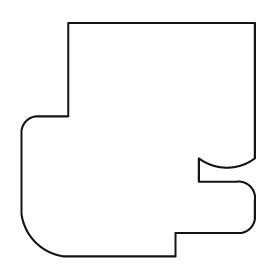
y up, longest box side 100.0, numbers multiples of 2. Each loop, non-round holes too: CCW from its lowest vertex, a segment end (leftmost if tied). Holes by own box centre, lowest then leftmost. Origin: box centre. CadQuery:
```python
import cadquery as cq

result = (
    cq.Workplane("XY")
    .moveTo(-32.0, -50.0)
    .lineTo(16.0, -50.0)
    .lineTo(16.0, -40.0)
    .lineTo(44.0, -40.0)
    .threePointArc((48.0, -38.0), (50.0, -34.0))
    .lineTo(50.0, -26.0)
    .threePointArc((48.0, -20.0), (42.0, -18.0))
    .lineTo(26.0, -18.0)
    .lineTo(26.0, -8.0)
    .threePointArc((38.0, -12.0), (50.0, -8.0))
    .lineTo(50.0, 50.0)
    .lineTo(-30.0, 50.0)
    .lineTo(-30.0, 10.0)
    .lineTo(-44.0, 10.0)
    .threePointArc((-48.0, 8.0), (-50.0, 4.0))
    .lineTo(-50.0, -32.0)
    .threePointArc((-44.0, -44.0), (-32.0, -50.0))
    .close()
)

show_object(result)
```